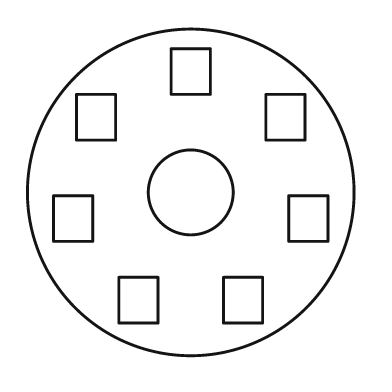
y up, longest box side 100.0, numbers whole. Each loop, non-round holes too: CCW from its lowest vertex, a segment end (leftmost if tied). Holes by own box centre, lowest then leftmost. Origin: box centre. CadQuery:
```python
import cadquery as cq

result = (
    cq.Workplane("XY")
    .moveTo(0.0, 0.0)
    .circle(50.0)
    .moveTo(-22.0, -40.0)
    .lineTo(-10.0, -40.0)
    .lineTo(-10.0, -26.0)
    .lineTo(-22.0, -26.0)
    .close()
    .moveTo(10.0, -40.0)
    .lineTo(22.0, -40.0)
    .lineTo(22.0, -26.0)
    .lineTo(10.0, -26.0)
    .close()
    .moveTo(-42.0, -15.0)
    .lineTo(-30.0, -15.0)
    .lineTo(-30.0, -1.0)
    .lineTo(-42.0, -1.0)
    .close()
    .moveTo(30.0, -15.0)
    .lineTo(42.0, -15.0)
    .lineTo(42.0, -1.0)
    .lineTo(30.0, -1.0)
    .close()
    .moveTo(0.0, 0.0)
    .circle(13.0)
    .moveTo(-35.0, 16.0)
    .lineTo(-23.0, 16.0)
    .lineTo(-23.0, 30.0)
    .lineTo(-35.0, 30.0)
    .close()
    .moveTo(23.0, 16.0)
    .lineTo(35.0, 16.0)
    .lineTo(35.0, 30.0)
    .lineTo(23.0, 30.0)
    .close()
    .moveTo(-6.0, 30.0)
    .lineTo(6.0, 30.0)
    .lineTo(6.0, 44.0)
    .lineTo(-6.0, 44.0)
    .close()
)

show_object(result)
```